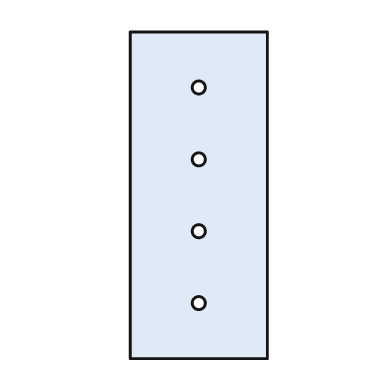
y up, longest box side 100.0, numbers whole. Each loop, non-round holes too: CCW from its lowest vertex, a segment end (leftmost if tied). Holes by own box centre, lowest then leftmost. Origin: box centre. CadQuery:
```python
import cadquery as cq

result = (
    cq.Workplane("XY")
    .moveTo(-21.0, -50.0)
    .lineTo(21.0, -50.0)
    .lineTo(21.0, 50.0)
    .lineTo(-21.0, 50.0)
    .close()
    .moveTo(0.0, -33.0)
    .circle(2.0)
    .moveTo(0.0, -11.0)
    .circle(2.0)
    .moveTo(0.0, 11.0)
    .circle(2.0)
    .moveTo(0.0, 33.0)
    .circle(2.0)
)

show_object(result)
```